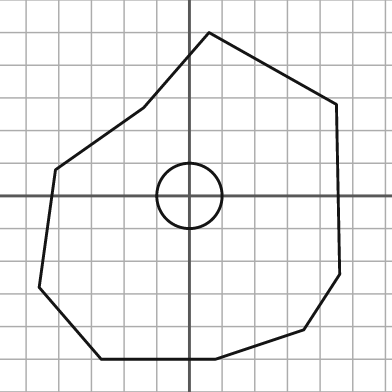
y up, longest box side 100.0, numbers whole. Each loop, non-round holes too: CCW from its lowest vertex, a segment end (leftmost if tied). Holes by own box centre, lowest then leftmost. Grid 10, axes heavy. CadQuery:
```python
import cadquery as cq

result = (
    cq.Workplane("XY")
    .moveTo(-27.0, -50.0)
    .lineTo(8.0, -50.0)
    .lineTo(35.0, -41.0)
    .lineTo(46.0, -24.0)
    .lineTo(45.0, 28.0)
    .lineTo(6.0, 50.0)
    .lineTo(-14.0, 27.0)
    .lineTo(-41.0, 8.0)
    .lineTo(-46.0, -28.0)
    .close()
    .moveTo(0.0, 0.0)
    .circle(10.0)
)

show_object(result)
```